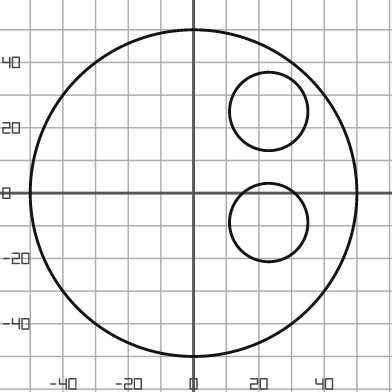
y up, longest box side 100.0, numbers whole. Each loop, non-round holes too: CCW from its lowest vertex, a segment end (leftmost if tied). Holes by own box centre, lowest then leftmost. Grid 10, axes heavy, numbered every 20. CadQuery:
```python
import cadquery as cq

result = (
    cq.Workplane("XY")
    .moveTo(0.0, 0.0)
    .circle(50.0)
    .moveTo(23.0, -9.0)
    .circle(12.0)
    .moveTo(23.0, 25.0)
    .circle(12.0)
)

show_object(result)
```